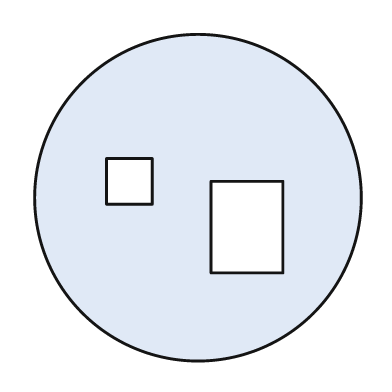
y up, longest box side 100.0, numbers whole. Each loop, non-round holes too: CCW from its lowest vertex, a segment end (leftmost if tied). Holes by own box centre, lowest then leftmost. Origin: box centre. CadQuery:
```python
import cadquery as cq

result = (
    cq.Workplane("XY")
    .moveTo(0.0, 0.0)
    .circle(50.0)
    .moveTo(4.0, -23.0)
    .lineTo(26.0, -23.0)
    .lineTo(26.0, 5.0)
    .lineTo(4.0, 5.0)
    .close()
    .moveTo(-28.0, -2.0)
    .lineTo(-14.0, -2.0)
    .lineTo(-14.0, 12.0)
    .lineTo(-28.0, 12.0)
    .close()
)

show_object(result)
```